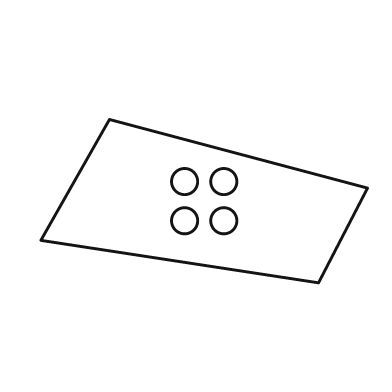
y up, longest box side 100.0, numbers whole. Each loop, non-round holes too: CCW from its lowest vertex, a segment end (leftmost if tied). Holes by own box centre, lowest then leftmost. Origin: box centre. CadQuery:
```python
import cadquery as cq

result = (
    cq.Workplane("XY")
    .moveTo(35.0, -25.0)
    .lineTo(50.0, 4.0)
    .lineTo(-29.0, 25.0)
    .lineTo(-50.0, -12.0)
    .close()
    .moveTo(-6.0, -6.0)
    .circle(4.0)
    .moveTo(6.0, -6.0)
    .circle(4.0)
    .moveTo(-6.0, 6.0)
    .circle(4.0)
    .moveTo(6.0, 6.0)
    .circle(4.0)
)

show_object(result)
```